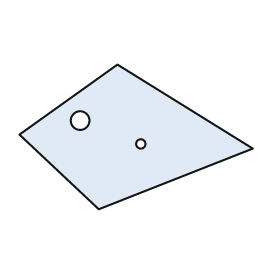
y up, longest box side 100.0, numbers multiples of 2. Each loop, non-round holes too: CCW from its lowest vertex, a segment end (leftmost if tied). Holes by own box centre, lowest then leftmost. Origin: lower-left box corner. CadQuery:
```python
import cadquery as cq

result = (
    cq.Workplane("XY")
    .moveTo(34.0, 0.0)
    .lineTo(100.0, 26.0)
    .lineTo(42.0, 62.0)
    .lineTo(0.0, 32.0)
    .close()
    .moveTo(52.0, 28.0)
    .circle(2.0)
    .moveTo(26.0, 38.0)
    .circle(4.0)
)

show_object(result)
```